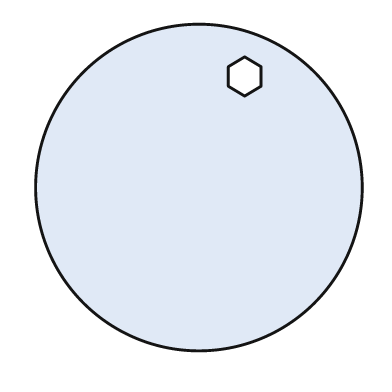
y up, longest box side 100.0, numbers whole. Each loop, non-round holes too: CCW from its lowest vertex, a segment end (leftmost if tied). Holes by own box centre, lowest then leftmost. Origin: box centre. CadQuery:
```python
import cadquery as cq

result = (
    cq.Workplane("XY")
    .moveTo(0.0, 0.0)
    .circle(50.0)
    .moveTo(14.0, 28.0)
    .lineTo(19.0, 31.0)
    .lineTo(19.0, 37.0)
    .lineTo(14.0, 40.0)
    .lineTo(9.0, 37.0)
    .lineTo(9.0, 31.0)
    .close()
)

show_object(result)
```